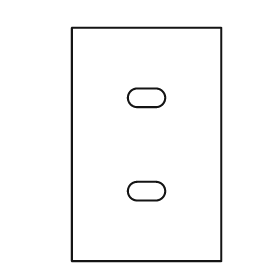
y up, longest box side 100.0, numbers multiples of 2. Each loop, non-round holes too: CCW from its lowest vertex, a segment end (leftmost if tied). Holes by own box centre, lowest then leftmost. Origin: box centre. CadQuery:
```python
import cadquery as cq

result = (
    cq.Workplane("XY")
    .moveTo(-32.0, -50.0)
    .lineTo(32.0, -50.0)
    .lineTo(32.0, 50.0)
    .lineTo(-32.0, 50.0)
    .close()
    .moveTo(-4.0, -24.0)
    .lineTo(4.0, -24.0)
    .threePointArc((8.0, -20.0), (4.0, -16.0))
    .lineTo(-4.0, -16.0)
    .threePointArc((-8.0, -20.0), (-4.0, -24.0))
    .close()
    .moveTo(-4.0, 16.0)
    .lineTo(4.0, 16.0)
    .threePointArc((8.0, 20.0), (4.0, 24.0))
    .lineTo(-4.0, 24.0)
    .threePointArc((-8.0, 20.0), (-4.0, 16.0))
    .close()
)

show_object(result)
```